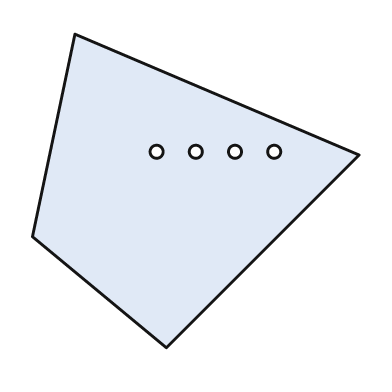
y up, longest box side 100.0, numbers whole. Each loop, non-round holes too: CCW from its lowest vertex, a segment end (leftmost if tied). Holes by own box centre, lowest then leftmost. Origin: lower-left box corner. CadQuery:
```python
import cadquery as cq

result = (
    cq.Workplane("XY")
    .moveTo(41.0, 0.0)
    .lineTo(100.0, 59.0)
    .lineTo(13.0, 96.0)
    .lineTo(0.0, 34.0)
    .close()
    .moveTo(38.0, 60.0)
    .circle(2.0)
    .moveTo(50.0, 60.0)
    .circle(2.0)
    .moveTo(62.0, 60.0)
    .circle(2.0)
    .moveTo(74.0, 60.0)
    .circle(2.0)
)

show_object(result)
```